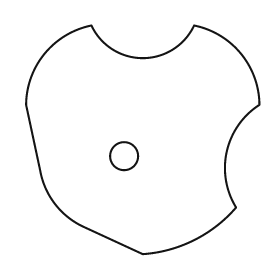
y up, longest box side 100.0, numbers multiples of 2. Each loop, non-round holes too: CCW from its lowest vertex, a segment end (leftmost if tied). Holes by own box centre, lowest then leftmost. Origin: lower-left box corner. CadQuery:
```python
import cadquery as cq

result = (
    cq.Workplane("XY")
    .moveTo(50.0, 0.0)
    .threePointArc((72.0, 6.0), (90.0, 20.0))
    .threePointArc((86.0, 44.0), (100.0, 64.0))
    .threePointArc((92.0, 86.0), (72.0, 98.0))
    .threePointArc((50.0, 84.0), (28.0, 98.0))
    .threePointArc((8.0, 86.0), (0.0, 64.0))
    .lineTo(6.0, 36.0)
    .threePointArc((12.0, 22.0), (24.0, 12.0))
    .close()
    .moveTo(42.0, 42.0)
    .circle(6.0)
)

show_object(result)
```